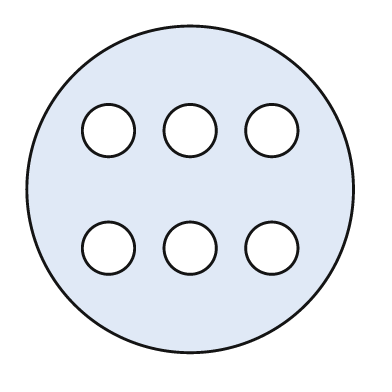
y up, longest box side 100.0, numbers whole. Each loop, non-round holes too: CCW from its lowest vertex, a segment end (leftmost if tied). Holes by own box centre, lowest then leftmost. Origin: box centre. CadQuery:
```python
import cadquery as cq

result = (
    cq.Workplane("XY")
    .moveTo(0.0, 0.0)
    .circle(50.0)
    .moveTo(-25.0, -18.0)
    .circle(8.0)
    .moveTo(0.0, -18.0)
    .circle(8.0)
    .moveTo(25.0, -18.0)
    .circle(8.0)
    .moveTo(-25.0, 18.0)
    .circle(8.0)
    .moveTo(0.0, 18.0)
    .circle(8.0)
    .moveTo(25.0, 18.0)
    .circle(8.0)
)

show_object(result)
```